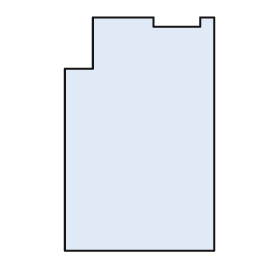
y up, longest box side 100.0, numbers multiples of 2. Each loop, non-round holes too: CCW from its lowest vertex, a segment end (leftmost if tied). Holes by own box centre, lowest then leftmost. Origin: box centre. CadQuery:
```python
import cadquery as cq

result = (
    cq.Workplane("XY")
    .moveTo(-32.0, -50.0)
    .lineTo(32.0, -50.0)
    .lineTo(32.0, 50.0)
    .lineTo(26.0, 50.0)
    .lineTo(26.0, 46.0)
    .lineTo(6.0, 46.0)
    .lineTo(6.0, 50.0)
    .lineTo(-20.0, 50.0)
    .lineTo(-20.0, 28.0)
    .lineTo(-32.0, 28.0)
    .close()
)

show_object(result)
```